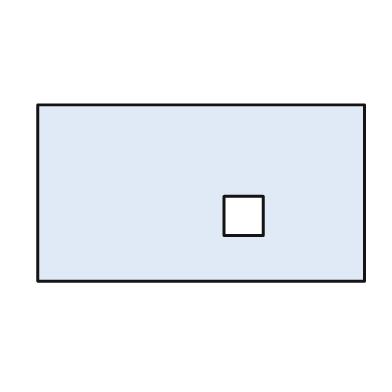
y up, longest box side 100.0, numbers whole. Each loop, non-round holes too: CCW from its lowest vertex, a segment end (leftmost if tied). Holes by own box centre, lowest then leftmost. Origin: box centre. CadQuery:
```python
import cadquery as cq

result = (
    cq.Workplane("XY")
    .moveTo(-50.0, -27.0)
    .lineTo(50.0, -27.0)
    .lineTo(50.0, 27.0)
    .lineTo(-50.0, 27.0)
    .close()
    .moveTo(7.0, -13.0)
    .lineTo(19.0, -13.0)
    .lineTo(19.0, -1.0)
    .lineTo(7.0, -1.0)
    .close()
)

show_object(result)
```